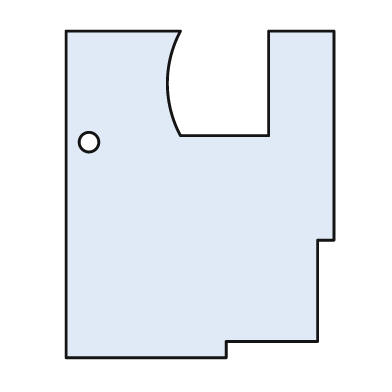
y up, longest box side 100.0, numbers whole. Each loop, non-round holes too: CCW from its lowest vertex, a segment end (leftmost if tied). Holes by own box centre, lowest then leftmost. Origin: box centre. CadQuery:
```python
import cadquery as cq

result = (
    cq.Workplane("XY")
    .moveTo(-41.0, -50.0)
    .lineTo(8.0, -50.0)
    .lineTo(8.0, -45.0)
    .lineTo(36.0, -45.0)
    .lineTo(36.0, -14.0)
    .lineTo(41.0, -14.0)
    .lineTo(41.0, 50.0)
    .lineTo(21.0, 50.0)
    .lineTo(21.0, 18.0)
    .lineTo(-6.0, 18.0)
    .threePointArc((-10.0, 34.0), (-6.0, 50.0))
    .lineTo(-41.0, 50.0)
    .close()
    .moveTo(-34.0, 16.0)
    .circle(3.0)
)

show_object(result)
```